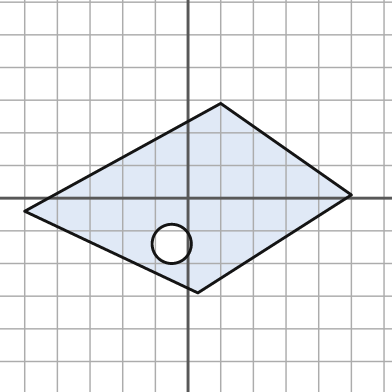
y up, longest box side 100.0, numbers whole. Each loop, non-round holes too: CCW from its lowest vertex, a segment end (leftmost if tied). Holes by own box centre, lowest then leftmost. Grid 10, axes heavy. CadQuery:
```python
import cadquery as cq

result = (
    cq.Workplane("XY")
    .moveTo(3.0, -29.0)
    .lineTo(50.0, 1.0)
    .lineTo(10.0, 29.0)
    .lineTo(-50.0, -4.0)
    .close()
    .moveTo(-5.0, -14.0)
    .circle(6.0)
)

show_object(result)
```